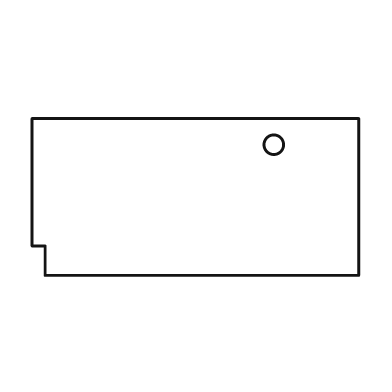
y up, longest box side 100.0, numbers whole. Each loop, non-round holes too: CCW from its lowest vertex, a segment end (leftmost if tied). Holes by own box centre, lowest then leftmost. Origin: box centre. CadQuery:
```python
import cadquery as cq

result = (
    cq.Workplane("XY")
    .moveTo(-46.0, -24.0)
    .lineTo(50.0, -24.0)
    .lineTo(50.0, 24.0)
    .lineTo(-50.0, 24.0)
    .lineTo(-50.0, -15.0)
    .lineTo(-46.0, -15.0)
    .close()
    .moveTo(24.0, 16.0)
    .circle(3.0)
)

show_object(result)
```